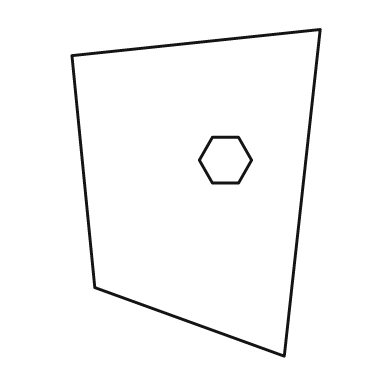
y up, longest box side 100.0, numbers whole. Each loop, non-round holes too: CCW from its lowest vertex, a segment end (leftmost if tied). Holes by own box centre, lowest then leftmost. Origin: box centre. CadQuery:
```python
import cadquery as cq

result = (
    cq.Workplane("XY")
    .moveTo(27.0, -50.0)
    .lineTo(38.0, 50.0)
    .lineTo(-38.0, 42.0)
    .lineTo(-31.0, -29.0)
    .close()
    .moveTo(5.0, 3.0)
    .lineTo(13.0, 3.0)
    .lineTo(17.0, 10.0)
    .lineTo(13.0, 17.0)
    .lineTo(5.0, 17.0)
    .lineTo(1.0, 10.0)
    .close()
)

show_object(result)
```